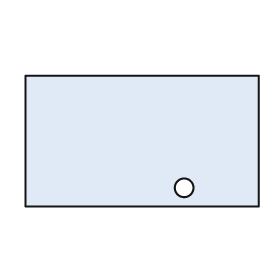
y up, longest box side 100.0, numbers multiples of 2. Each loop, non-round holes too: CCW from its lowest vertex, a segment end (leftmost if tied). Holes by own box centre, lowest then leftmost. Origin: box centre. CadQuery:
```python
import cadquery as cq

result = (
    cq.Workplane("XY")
    .moveTo(-50.0, -28.0)
    .lineTo(50.0, -28.0)
    .lineTo(50.0, 28.0)
    .lineTo(-50.0, 28.0)
    .close()
    .moveTo(18.0, -20.0)
    .circle(4.0)
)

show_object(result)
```